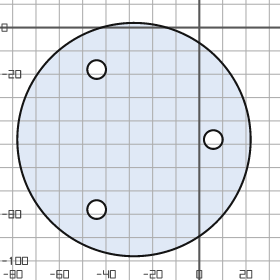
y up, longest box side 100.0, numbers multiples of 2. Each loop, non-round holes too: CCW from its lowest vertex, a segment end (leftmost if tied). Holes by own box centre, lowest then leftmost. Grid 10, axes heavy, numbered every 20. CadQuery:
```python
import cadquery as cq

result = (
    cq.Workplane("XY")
    .moveTo(-28.0, -48.0)
    .circle(50.0)
    .moveTo(-44.0, -78.0)
    .circle(4.0)
    .moveTo(6.0, -48.0)
    .circle(4.0)
    .moveTo(-44.0, -18.0)
    .circle(4.0)
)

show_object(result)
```